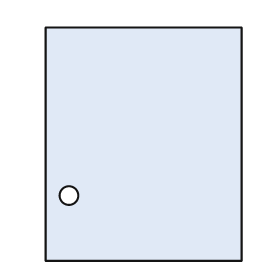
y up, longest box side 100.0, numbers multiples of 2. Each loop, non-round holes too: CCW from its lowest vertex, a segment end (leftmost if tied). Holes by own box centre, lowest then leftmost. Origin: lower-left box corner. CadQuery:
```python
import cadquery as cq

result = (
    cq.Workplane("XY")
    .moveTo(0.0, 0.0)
    .lineTo(84.0, 0.0)
    .lineTo(84.0, 100.0)
    .lineTo(0.0, 100.0)
    .close()
    .moveTo(10.0, 28.0)
    .circle(4.0)
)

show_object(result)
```